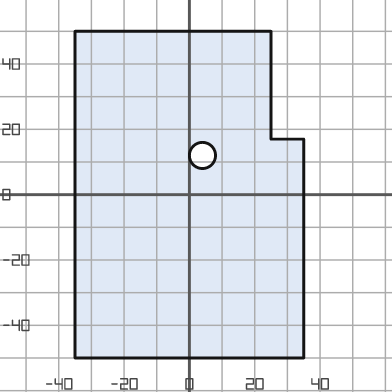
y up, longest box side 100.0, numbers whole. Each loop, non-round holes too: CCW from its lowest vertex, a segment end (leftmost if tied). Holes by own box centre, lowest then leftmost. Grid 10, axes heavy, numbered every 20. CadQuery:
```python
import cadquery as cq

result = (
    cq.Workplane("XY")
    .moveTo(-35.0, -50.0)
    .lineTo(35.0, -50.0)
    .lineTo(35.0, 17.0)
    .lineTo(25.0, 17.0)
    .lineTo(25.0, 50.0)
    .lineTo(-35.0, 50.0)
    .close()
    .moveTo(4.0, 12.0)
    .circle(4.0)
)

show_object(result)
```